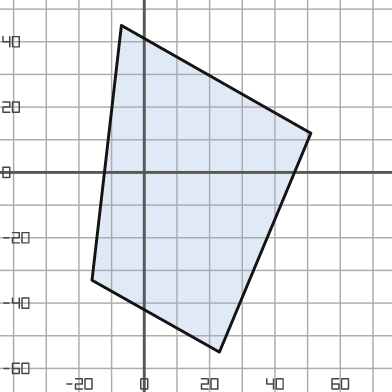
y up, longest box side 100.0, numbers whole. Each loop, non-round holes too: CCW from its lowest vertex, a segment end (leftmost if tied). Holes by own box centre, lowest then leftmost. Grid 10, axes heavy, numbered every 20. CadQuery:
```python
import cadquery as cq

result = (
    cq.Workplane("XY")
    .moveTo(23.0, -55.0)
    .lineTo(51.0, 12.0)
    .lineTo(-7.0, 45.0)
    .lineTo(-16.0, -33.0)
    .close()
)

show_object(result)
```